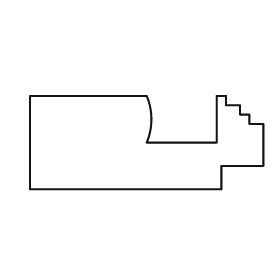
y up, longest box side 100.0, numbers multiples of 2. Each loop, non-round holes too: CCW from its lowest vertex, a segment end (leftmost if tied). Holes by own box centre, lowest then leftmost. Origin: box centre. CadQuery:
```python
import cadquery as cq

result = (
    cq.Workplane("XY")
    .moveTo(-50.0, -20.0)
    .lineTo(32.0, -20.0)
    .lineTo(32.0, -10.0)
    .lineTo(50.0, -10.0)
    .lineTo(50.0, 8.0)
    .lineTo(44.0, 8.0)
    .lineTo(44.0, 12.0)
    .lineTo(40.0, 12.0)
    .lineTo(40.0, 16.0)
    .lineTo(34.0, 16.0)
    .lineTo(34.0, 20.0)
    .lineTo(30.0, 20.0)
    .lineTo(30.0, 0.0)
    .lineTo(0.0, 0.0)
    .threePointArc((2.0, 10.0), (0.0, 20.0))
    .lineTo(-50.0, 20.0)
    .close()
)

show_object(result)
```